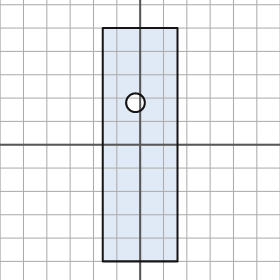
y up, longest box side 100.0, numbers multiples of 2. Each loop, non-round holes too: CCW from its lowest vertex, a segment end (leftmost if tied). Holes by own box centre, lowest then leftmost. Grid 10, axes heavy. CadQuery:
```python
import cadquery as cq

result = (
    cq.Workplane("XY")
    .moveTo(-16.0, -50.0)
    .lineTo(16.0, -50.0)
    .lineTo(16.0, 50.0)
    .lineTo(-16.0, 50.0)
    .close()
    .moveTo(-2.0, 18.0)
    .circle(4.0)
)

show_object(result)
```